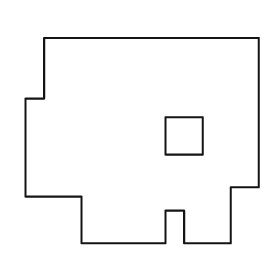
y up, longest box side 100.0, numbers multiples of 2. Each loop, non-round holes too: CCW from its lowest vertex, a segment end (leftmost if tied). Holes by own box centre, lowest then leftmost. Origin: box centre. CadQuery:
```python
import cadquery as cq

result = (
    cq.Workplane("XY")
    .moveTo(-26.0, -44.0)
    .lineTo(10.0, -44.0)
    .lineTo(10.0, -30.0)
    .lineTo(18.0, -30.0)
    .lineTo(18.0, -44.0)
    .lineTo(38.0, -44.0)
    .lineTo(38.0, -20.0)
    .lineTo(50.0, -20.0)
    .lineTo(50.0, 44.0)
    .lineTo(-42.0, 44.0)
    .lineTo(-42.0, 18.0)
    .lineTo(-50.0, 18.0)
    .lineTo(-50.0, -24.0)
    .lineTo(-26.0, -24.0)
    .close()
    .moveTo(10.0, -6.0)
    .lineTo(26.0, -6.0)
    .lineTo(26.0, 10.0)
    .lineTo(10.0, 10.0)
    .close()
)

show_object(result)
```